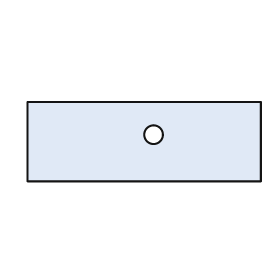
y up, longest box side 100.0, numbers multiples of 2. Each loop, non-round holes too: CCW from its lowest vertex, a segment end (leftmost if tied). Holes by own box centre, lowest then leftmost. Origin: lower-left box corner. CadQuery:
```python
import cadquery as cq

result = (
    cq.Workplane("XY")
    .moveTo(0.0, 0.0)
    .lineTo(100.0, 0.0)
    .lineTo(100.0, 34.0)
    .lineTo(0.0, 34.0)
    .close()
    .moveTo(54.0, 20.0)
    .circle(4.0)
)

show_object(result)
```